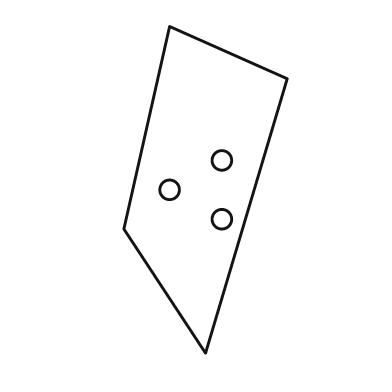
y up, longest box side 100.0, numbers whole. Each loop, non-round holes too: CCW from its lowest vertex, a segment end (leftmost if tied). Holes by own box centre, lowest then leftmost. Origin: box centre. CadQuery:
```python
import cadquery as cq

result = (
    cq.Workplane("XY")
    .moveTo(0.0, -50.0)
    .lineTo(25.0, 34.0)
    .lineTo(-11.0, 50.0)
    .lineTo(-25.0, -12.0)
    .close()
    .moveTo(5.0, -9.0)
    .circle(3.0)
    .moveTo(-11.0, 0.0)
    .circle(3.0)
    .moveTo(5.0, 9.0)
    .circle(3.0)
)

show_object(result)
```